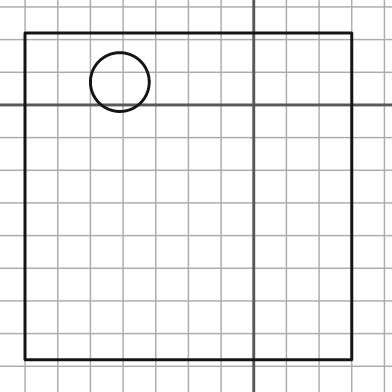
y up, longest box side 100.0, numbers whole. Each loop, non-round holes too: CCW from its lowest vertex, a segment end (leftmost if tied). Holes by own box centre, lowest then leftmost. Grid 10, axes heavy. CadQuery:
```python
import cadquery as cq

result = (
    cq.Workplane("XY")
    .moveTo(-70.0, -78.0)
    .lineTo(30.0, -78.0)
    .lineTo(30.0, 22.0)
    .lineTo(-70.0, 22.0)
    .close()
    .moveTo(-41.0, 7.0)
    .circle(9.0)
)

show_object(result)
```